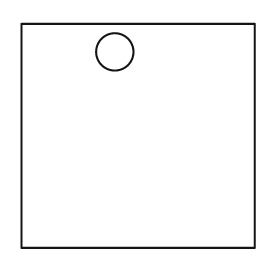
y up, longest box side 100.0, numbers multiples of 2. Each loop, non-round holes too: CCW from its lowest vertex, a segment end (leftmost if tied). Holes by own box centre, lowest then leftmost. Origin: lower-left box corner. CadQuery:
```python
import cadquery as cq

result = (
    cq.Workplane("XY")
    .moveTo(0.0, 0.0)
    .lineTo(100.0, 0.0)
    .lineTo(100.0, 96.0)
    .lineTo(0.0, 96.0)
    .close()
    .moveTo(40.0, 84.0)
    .circle(8.0)
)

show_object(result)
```